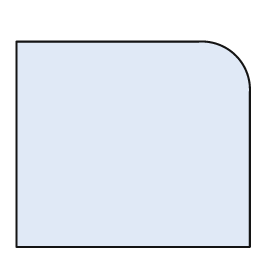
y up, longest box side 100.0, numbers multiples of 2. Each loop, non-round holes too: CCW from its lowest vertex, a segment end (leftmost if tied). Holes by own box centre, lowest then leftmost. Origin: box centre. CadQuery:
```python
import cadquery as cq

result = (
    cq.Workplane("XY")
    .moveTo(-50.0, -44.0)
    .lineTo(50.0, -44.0)
    .lineTo(50.0, 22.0)
    .threePointArc((44.0, 38.0), (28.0, 44.0))
    .lineTo(-50.0, 44.0)
    .close()
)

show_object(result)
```